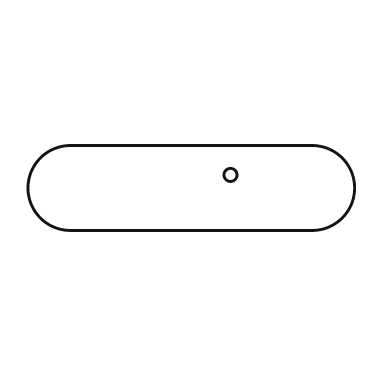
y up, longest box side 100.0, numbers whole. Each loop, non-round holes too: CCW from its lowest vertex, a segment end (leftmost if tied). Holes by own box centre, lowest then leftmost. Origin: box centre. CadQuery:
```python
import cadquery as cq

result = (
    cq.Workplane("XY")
    .moveTo(-37.0, -13.0)
    .lineTo(37.0, -13.0)
    .threePointArc((50.0, 0.0), (37.0, 13.0))
    .lineTo(-37.0, 13.0)
    .threePointArc((-50.0, 0.0), (-37.0, -13.0))
    .close()
    .moveTo(12.0, 4.0)
    .circle(2.0)
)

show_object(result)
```